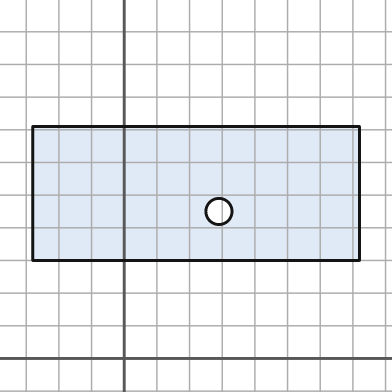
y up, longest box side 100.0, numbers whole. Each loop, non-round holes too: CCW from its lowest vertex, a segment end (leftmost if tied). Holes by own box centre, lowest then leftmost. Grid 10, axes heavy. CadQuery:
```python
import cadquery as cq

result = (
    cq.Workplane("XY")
    .moveTo(-28.0, 30.0)
    .lineTo(72.0, 30.0)
    .lineTo(72.0, 71.0)
    .lineTo(-28.0, 71.0)
    .close()
    .moveTo(29.0, 45.0)
    .circle(4.0)
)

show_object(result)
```